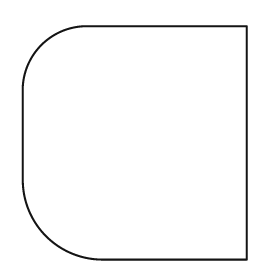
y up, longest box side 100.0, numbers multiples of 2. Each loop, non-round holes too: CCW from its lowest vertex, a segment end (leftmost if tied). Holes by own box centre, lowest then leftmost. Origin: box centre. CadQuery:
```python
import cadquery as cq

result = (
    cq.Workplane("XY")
    .moveTo(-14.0, -50.0)
    .lineTo(48.0, -50.0)
    .lineTo(48.0, 50.0)
    .lineTo(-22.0, 50.0)
    .threePointArc((-40.0, 42.0), (-48.0, 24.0))
    .lineTo(-48.0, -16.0)
    .threePointArc((-38.0, -40.0), (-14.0, -50.0))
    .close()
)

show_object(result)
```